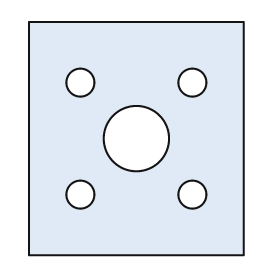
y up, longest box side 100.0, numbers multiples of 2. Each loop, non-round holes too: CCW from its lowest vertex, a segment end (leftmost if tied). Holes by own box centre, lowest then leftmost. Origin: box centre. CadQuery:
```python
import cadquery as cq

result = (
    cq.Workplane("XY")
    .moveTo(-46.0, -50.0)
    .lineTo(46.0, -50.0)
    .lineTo(46.0, 50.0)
    .lineTo(-46.0, 50.0)
    .close()
    .moveTo(-24.0, -24.0)
    .circle(6.0)
    .moveTo(24.0, -24.0)
    .circle(6.0)
    .moveTo(0.0, 0.0)
    .circle(14.0)
    .moveTo(-24.0, 24.0)
    .circle(6.0)
    .moveTo(24.0, 24.0)
    .circle(6.0)
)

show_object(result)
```